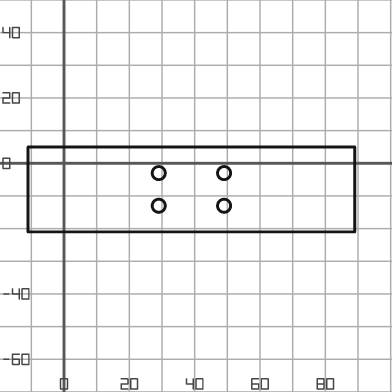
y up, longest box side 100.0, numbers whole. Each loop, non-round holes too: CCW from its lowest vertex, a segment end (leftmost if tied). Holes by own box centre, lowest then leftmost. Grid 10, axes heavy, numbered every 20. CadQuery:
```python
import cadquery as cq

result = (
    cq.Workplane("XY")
    .moveTo(-11.0, -21.0)
    .lineTo(89.0, -21.0)
    .lineTo(89.0, 5.0)
    .lineTo(-11.0, 5.0)
    .close()
    .moveTo(29.0, -13.0)
    .circle(2.0)
    .moveTo(49.0, -13.0)
    .circle(2.0)
    .moveTo(29.0, -3.0)
    .circle(2.0)
    .moveTo(49.0, -3.0)
    .circle(2.0)
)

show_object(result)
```